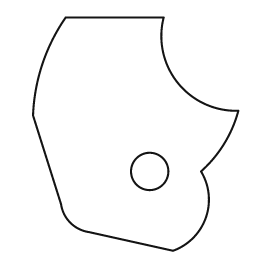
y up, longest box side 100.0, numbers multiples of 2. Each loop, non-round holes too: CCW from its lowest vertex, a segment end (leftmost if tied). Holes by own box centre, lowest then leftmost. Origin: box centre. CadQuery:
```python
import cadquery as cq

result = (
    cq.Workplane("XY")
    .moveTo(16.0, -50.0)
    .threePointArc((30.0, -36.0), (28.0, -16.0))
    .threePointArc((38.0, -4.0), (44.0, 10.0))
    .threePointArc((18.0, 22.0), (12.0, 50.0))
    .lineTo(-30.0, 50.0)
    .threePointArc((-40.0, 30.0), (-44.0, 8.0))
    .lineTo(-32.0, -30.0)
    .threePointArc((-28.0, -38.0), (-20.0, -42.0))
    .close()
    .moveTo(6.0, -16.0)
    .circle(8.0)
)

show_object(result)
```